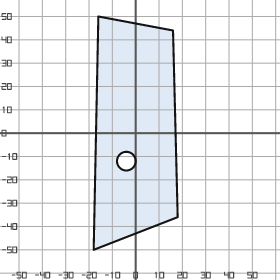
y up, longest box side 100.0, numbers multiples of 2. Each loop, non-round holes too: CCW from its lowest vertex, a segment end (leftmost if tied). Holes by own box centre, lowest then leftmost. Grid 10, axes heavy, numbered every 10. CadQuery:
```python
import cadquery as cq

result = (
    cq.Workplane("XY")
    .moveTo(-18.0, -50.0)
    .lineTo(18.0, -36.0)
    .lineTo(16.0, 44.0)
    .lineTo(-16.0, 50.0)
    .close()
    .moveTo(-4.0, -12.0)
    .circle(4.0)
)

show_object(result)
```